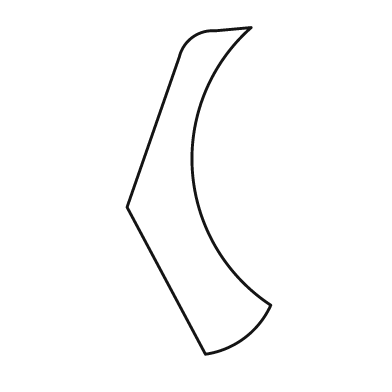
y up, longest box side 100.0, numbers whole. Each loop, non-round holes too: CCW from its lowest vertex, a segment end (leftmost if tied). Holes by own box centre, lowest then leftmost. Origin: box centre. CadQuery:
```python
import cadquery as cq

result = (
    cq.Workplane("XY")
    .moveTo(2.0, -50.0)
    .threePointArc((14.0, -45.0), (22.0, -35.0))
    .threePointArc((-2.0, 6.0), (16.0, 50.0))
    .lineTo(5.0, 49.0)
    .threePointArc((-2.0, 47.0), (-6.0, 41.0))
    .lineTo(-22.0, -5.0)
    .close()
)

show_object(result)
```